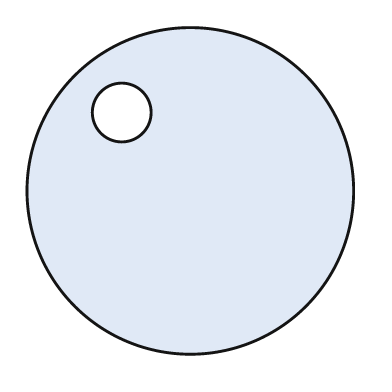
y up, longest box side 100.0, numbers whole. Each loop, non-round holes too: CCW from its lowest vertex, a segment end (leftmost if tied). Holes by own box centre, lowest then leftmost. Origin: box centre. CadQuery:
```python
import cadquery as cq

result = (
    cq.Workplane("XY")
    .moveTo(0.0, 0.0)
    .circle(50.0)
    .moveTo(-21.0, 24.0)
    .circle(9.0)
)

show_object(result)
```